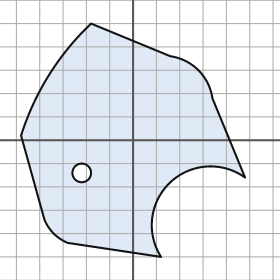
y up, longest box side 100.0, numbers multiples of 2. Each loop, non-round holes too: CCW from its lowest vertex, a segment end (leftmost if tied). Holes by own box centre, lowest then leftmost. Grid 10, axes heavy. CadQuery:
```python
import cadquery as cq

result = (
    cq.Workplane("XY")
    .moveTo(12.0, -50.0)
    .threePointArc((16.0, -18.0), (48.0, -16.0))
    .lineTo(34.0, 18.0)
    .threePointArc((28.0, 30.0), (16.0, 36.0))
    .lineTo(-18.0, 50.0)
    .threePointArc((-36.0, 28.0), (-48.0, 2.0))
    .lineTo(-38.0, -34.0)
    .threePointArc((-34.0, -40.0), (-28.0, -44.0))
    .close()
    .moveTo(-22.0, -14.0)
    .circle(4.0)
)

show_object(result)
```